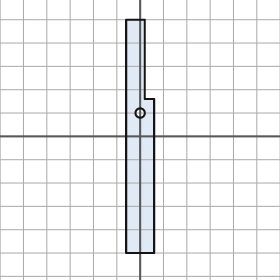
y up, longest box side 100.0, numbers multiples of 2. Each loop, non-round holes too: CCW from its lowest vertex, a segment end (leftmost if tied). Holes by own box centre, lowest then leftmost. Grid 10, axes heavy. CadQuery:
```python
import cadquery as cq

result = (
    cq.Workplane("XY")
    .moveTo(-6.0, -50.0)
    .lineTo(6.0, -50.0)
    .lineTo(6.0, 16.0)
    .lineTo(2.0, 16.0)
    .lineTo(2.0, 50.0)
    .lineTo(-6.0, 50.0)
    .close()
    .moveTo(0.0, 10.0)
    .circle(2.0)
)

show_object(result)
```